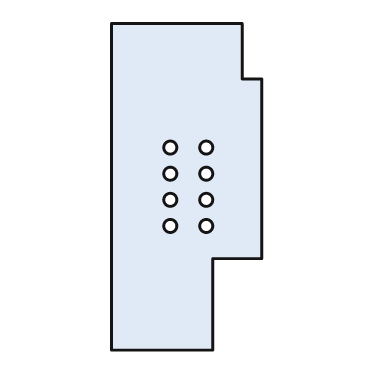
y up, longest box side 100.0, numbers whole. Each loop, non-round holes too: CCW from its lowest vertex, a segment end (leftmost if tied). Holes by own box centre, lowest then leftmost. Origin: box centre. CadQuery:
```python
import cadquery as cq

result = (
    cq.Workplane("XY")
    .moveTo(-23.0, -50.0)
    .lineTo(8.0, -50.0)
    .lineTo(8.0, -22.0)
    .lineTo(23.0, -22.0)
    .lineTo(23.0, 33.0)
    .lineTo(17.0, 33.0)
    .lineTo(17.0, 50.0)
    .lineTo(-23.0, 50.0)
    .close()
    .moveTo(-5.0, -12.0)
    .circle(2.0)
    .moveTo(6.0, -12.0)
    .circle(2.0)
    .moveTo(-5.0, -4.0)
    .circle(2.0)
    .moveTo(6.0, -4.0)
    .circle(2.0)
    .moveTo(-5.0, 4.0)
    .circle(2.0)
    .moveTo(6.0, 4.0)
    .circle(2.0)
    .moveTo(-5.0, 12.0)
    .circle(2.0)
    .moveTo(6.0, 12.0)
    .circle(2.0)
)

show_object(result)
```